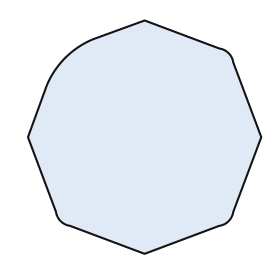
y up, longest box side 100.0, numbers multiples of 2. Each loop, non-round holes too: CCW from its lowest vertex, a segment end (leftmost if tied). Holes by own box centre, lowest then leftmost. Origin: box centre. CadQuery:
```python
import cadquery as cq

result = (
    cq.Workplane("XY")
    .moveTo(0.0, -50.0)
    .lineTo(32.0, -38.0)
    .threePointArc((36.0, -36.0), (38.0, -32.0))
    .lineTo(50.0, 0.0)
    .lineTo(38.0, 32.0)
    .threePointArc((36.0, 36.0), (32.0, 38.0))
    .lineTo(0.0, 50.0)
    .lineTo(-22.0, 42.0)
    .threePointArc((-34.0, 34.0), (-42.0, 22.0))
    .lineTo(-50.0, 0.0)
    .lineTo(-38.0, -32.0)
    .threePointArc((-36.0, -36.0), (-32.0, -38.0))
    .close()
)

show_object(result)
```